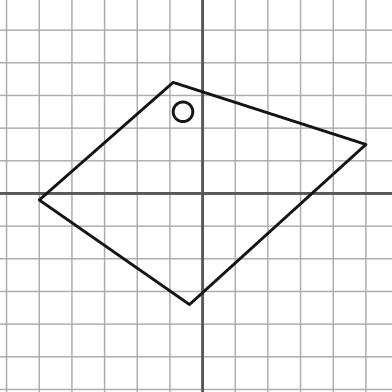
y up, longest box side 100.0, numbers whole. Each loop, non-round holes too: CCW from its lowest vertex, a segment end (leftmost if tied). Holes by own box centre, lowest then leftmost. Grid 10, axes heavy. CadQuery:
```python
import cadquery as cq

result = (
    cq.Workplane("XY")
    .moveTo(-4.0, -34.0)
    .lineTo(50.0, 15.0)
    .lineTo(-9.0, 34.0)
    .lineTo(-50.0, -2.0)
    .close()
    .moveTo(-6.0, 25.0)
    .circle(3.0)
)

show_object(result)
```